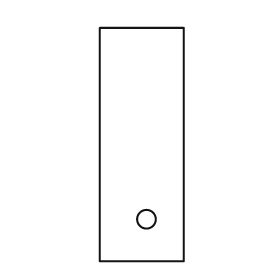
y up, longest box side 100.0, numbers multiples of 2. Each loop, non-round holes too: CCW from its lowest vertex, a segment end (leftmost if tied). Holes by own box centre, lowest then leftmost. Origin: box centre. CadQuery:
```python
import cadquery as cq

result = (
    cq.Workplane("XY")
    .moveTo(-18.0, -50.0)
    .lineTo(18.0, -50.0)
    .lineTo(18.0, 50.0)
    .lineTo(-18.0, 50.0)
    .close()
    .moveTo(2.0, -32.0)
    .circle(4.0)
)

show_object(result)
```